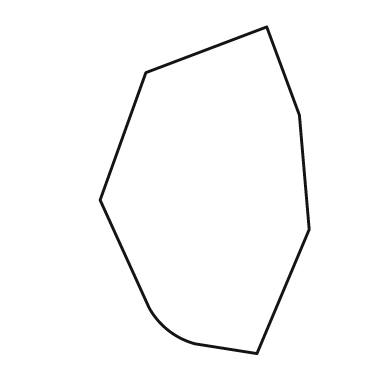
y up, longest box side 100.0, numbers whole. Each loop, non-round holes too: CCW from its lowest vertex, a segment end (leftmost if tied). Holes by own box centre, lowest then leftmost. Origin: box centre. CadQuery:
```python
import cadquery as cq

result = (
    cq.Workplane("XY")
    .moveTo(16.0, -50.0)
    .lineTo(32.0, -12.0)
    .lineTo(29.0, 23.0)
    .lineTo(19.0, 50.0)
    .lineTo(-18.0, 36.0)
    .lineTo(-32.0, -3.0)
    .lineTo(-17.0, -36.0)
    .threePointArc((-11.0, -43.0), (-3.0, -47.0))
    .close()
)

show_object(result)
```